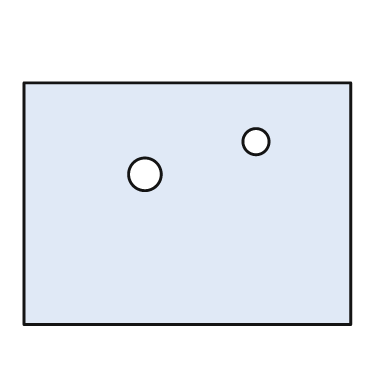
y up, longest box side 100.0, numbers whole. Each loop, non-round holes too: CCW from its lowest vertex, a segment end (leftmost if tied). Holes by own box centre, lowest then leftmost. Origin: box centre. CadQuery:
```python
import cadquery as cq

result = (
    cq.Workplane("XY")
    .moveTo(-50.0, -37.0)
    .lineTo(50.0, -37.0)
    .lineTo(50.0, 37.0)
    .lineTo(-50.0, 37.0)
    .close()
    .moveTo(-13.0, 9.0)
    .circle(5.0)
    .moveTo(21.0, 19.0)
    .circle(4.0)
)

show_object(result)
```